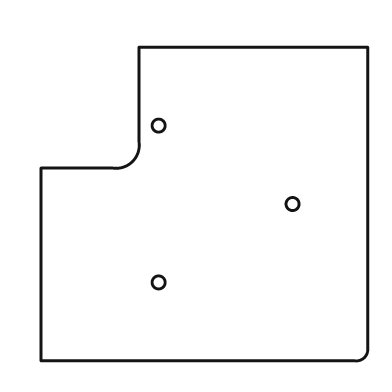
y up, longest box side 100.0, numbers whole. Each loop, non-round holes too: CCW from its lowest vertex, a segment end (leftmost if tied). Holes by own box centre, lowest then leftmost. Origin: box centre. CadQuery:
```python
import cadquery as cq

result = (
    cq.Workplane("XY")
    .moveTo(-50.0, -48.0)
    .lineTo(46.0, -48.0)
    .threePointArc((49.0, -47.0), (50.0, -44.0))
    .lineTo(50.0, 48.0)
    .lineTo(-20.0, 48.0)
    .lineTo(-20.0, 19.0)
    .threePointArc((-22.0, 13.0), (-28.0, 11.0))
    .lineTo(-50.0, 11.0)
    .close()
    .moveTo(-14.0, -24.0)
    .circle(2.0)
    .moveTo(27.0, 0.0)
    .circle(2.0)
    .moveTo(-14.0, 24.0)
    .circle(2.0)
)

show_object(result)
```